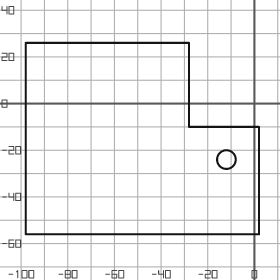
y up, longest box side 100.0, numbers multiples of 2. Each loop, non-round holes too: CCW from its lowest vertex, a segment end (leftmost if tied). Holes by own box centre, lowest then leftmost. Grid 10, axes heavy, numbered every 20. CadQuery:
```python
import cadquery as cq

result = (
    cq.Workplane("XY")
    .moveTo(-98.0, -56.0)
    .lineTo(2.0, -56.0)
    .lineTo(2.0, -10.0)
    .lineTo(-28.0, -10.0)
    .lineTo(-28.0, 26.0)
    .lineTo(-98.0, 26.0)
    .close()
    .moveTo(-12.0, -24.0)
    .circle(4.0)
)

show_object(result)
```